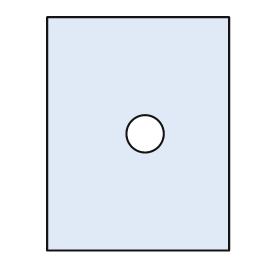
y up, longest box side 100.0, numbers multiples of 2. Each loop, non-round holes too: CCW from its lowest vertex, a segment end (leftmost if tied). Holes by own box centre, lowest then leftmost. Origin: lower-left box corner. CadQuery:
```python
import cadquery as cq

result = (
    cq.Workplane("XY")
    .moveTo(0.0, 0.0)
    .lineTo(78.0, 0.0)
    .lineTo(78.0, 100.0)
    .lineTo(0.0, 100.0)
    .close()
    .moveTo(42.0, 50.0)
    .circle(8.0)
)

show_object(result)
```